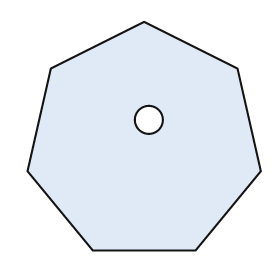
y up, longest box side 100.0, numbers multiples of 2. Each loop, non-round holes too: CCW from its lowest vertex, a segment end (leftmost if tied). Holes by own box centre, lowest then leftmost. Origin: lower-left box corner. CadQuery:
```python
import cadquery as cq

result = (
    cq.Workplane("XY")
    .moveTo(28.0, 0.0)
    .lineTo(72.0, 0.0)
    .lineTo(100.0, 34.0)
    .lineTo(90.0, 78.0)
    .lineTo(50.0, 98.0)
    .lineTo(10.0, 78.0)
    .lineTo(0.0, 34.0)
    .close()
    .moveTo(52.0, 56.0)
    .circle(6.0)
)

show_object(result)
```